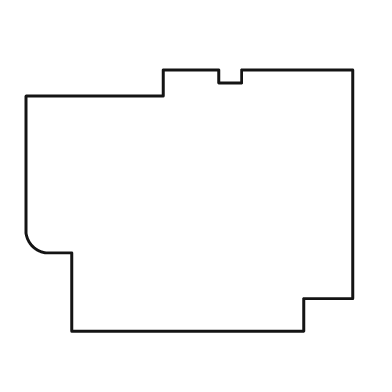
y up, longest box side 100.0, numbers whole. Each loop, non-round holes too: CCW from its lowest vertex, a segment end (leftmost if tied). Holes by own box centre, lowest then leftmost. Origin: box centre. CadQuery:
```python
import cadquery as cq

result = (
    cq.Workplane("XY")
    .moveTo(-36.0, -40.0)
    .lineTo(35.0, -40.0)
    .lineTo(35.0, -30.0)
    .lineTo(50.0, -30.0)
    .lineTo(50.0, 40.0)
    .lineTo(16.0, 40.0)
    .lineTo(16.0, 36.0)
    .lineTo(9.0, 36.0)
    .lineTo(9.0, 40.0)
    .lineTo(-8.0, 40.0)
    .lineTo(-8.0, 32.0)
    .lineTo(-50.0, 32.0)
    .lineTo(-50.0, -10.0)
    .threePointArc((-48.0, -14.0), (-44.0, -16.0))
    .lineTo(-36.0, -16.0)
    .close()
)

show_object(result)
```